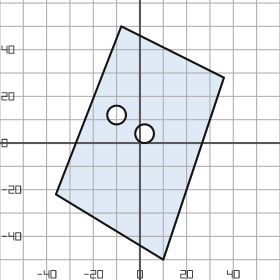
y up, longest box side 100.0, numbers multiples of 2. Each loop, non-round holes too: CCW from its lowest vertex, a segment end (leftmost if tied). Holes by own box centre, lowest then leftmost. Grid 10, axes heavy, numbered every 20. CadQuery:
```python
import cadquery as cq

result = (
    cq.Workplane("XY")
    .moveTo(10.0, -50.0)
    .lineTo(36.0, 28.0)
    .lineTo(-8.0, 50.0)
    .lineTo(-36.0, -22.0)
    .close()
    .moveTo(2.0, 4.0)
    .circle(4.0)
    .moveTo(-10.0, 12.0)
    .circle(4.0)
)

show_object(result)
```